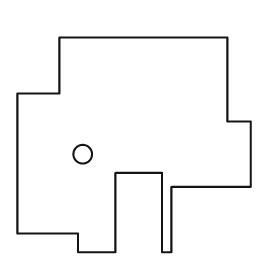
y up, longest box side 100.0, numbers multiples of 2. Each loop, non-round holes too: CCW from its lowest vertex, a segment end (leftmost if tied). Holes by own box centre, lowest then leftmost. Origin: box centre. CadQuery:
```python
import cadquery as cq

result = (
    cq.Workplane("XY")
    .moveTo(-24.0, -46.0)
    .lineTo(-8.0, -46.0)
    .lineTo(-8.0, -12.0)
    .lineTo(12.0, -12.0)
    .lineTo(12.0, -46.0)
    .lineTo(16.0, -46.0)
    .lineTo(16.0, -18.0)
    .lineTo(50.0, -18.0)
    .lineTo(50.0, 10.0)
    .lineTo(40.0, 10.0)
    .lineTo(40.0, 46.0)
    .lineTo(-32.0, 46.0)
    .lineTo(-32.0, 22.0)
    .lineTo(-50.0, 22.0)
    .lineTo(-50.0, -38.0)
    .lineTo(-24.0, -38.0)
    .close()
    .moveTo(-22.0, -4.0)
    .circle(4.0)
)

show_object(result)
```